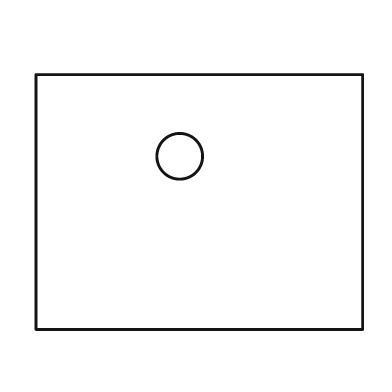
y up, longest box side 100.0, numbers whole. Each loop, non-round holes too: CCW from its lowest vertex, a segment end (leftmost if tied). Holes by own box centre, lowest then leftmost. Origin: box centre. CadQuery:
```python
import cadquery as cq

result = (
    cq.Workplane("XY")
    .moveTo(-50.0, -39.0)
    .lineTo(50.0, -39.0)
    .lineTo(50.0, 39.0)
    .lineTo(-50.0, 39.0)
    .close()
    .moveTo(-6.0, 14.0)
    .circle(7.0)
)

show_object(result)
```